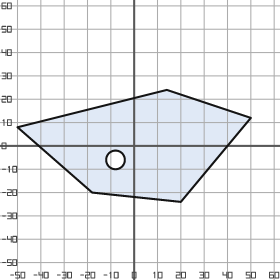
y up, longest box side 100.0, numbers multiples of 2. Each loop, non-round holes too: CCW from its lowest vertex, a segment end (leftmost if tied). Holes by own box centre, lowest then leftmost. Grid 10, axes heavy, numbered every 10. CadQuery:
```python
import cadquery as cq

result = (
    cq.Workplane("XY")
    .moveTo(20.0, -24.0)
    .lineTo(50.0, 12.0)
    .lineTo(14.0, 24.0)
    .lineTo(-50.0, 8.0)
    .lineTo(-18.0, -20.0)
    .close()
    .moveTo(-8.0, -6.0)
    .circle(4.0)
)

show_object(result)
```